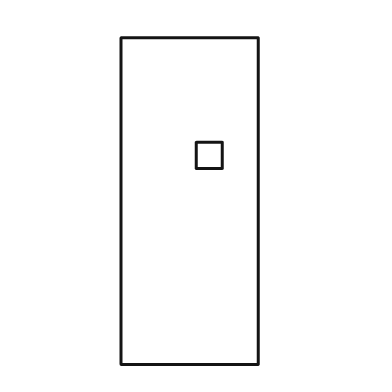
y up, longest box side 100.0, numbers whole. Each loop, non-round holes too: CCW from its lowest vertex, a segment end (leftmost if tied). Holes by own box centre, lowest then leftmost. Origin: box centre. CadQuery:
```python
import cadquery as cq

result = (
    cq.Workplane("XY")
    .moveTo(-21.0, -50.0)
    .lineTo(21.0, -50.0)
    .lineTo(21.0, 50.0)
    .lineTo(-21.0, 50.0)
    .close()
    .moveTo(2.0, 10.0)
    .lineTo(10.0, 10.0)
    .lineTo(10.0, 18.0)
    .lineTo(2.0, 18.0)
    .close()
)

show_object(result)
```